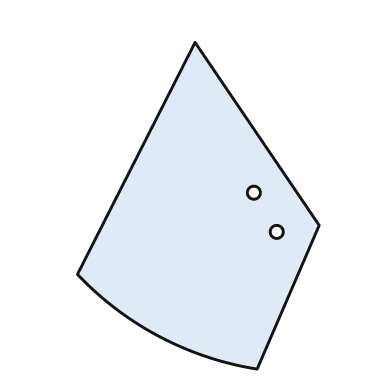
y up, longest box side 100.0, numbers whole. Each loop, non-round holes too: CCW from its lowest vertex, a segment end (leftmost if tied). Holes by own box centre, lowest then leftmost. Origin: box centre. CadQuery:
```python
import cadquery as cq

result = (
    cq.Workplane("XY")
    .moveTo(18.0, -50.0)
    .lineTo(37.0, -6.0)
    .lineTo(-1.0, 50.0)
    .lineTo(-37.0, -21.0)
    .threePointArc((-12.0, -40.0), (18.0, -50.0))
    .close()
    .moveTo(24.0, -8.0)
    .circle(2.0)
    .moveTo(17.0, 4.0)
    .circle(2.0)
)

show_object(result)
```